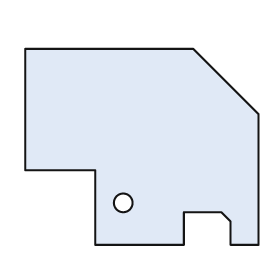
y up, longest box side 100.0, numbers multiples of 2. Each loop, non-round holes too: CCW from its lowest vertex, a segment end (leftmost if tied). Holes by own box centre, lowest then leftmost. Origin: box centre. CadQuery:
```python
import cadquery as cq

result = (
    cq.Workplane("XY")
    .moveTo(-20.0, -42.0)
    .lineTo(18.0, -42.0)
    .lineTo(18.0, -28.0)
    .lineTo(34.0, -28.0)
    .lineTo(38.0, -32.0)
    .lineTo(38.0, -42.0)
    .lineTo(50.0, -42.0)
    .lineTo(50.0, 14.0)
    .lineTo(22.0, 42.0)
    .lineTo(-50.0, 42.0)
    .lineTo(-50.0, -10.0)
    .lineTo(-20.0, -10.0)
    .close()
    .moveTo(-8.0, -24.0)
    .circle(4.0)
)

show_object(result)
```